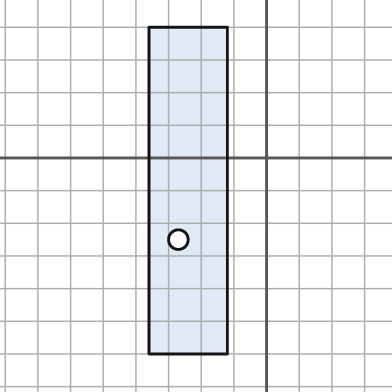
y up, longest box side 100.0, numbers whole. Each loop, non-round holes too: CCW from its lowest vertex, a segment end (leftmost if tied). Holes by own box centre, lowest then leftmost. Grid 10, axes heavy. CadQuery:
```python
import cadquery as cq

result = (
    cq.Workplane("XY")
    .moveTo(-36.0, -60.0)
    .lineTo(-12.0, -60.0)
    .lineTo(-12.0, 40.0)
    .lineTo(-36.0, 40.0)
    .close()
    .moveTo(-27.0, -25.0)
    .circle(3.0)
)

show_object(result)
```